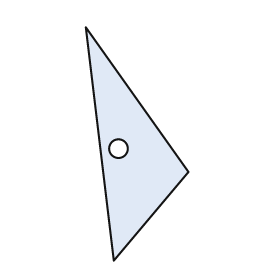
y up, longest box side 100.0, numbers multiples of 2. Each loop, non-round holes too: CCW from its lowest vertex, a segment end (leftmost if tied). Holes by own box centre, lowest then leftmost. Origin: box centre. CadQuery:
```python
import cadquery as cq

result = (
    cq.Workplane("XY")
    .moveTo(-10.0, -50.0)
    .lineTo(22.0, -12.0)
    .lineTo(-22.0, 50.0)
    .close()
    .moveTo(-8.0, -2.0)
    .circle(4.0)
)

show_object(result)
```